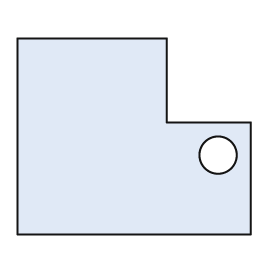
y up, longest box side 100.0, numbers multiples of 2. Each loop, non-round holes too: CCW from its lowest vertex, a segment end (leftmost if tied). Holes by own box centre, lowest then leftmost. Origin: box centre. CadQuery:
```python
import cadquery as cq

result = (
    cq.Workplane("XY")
    .moveTo(-50.0, -42.0)
    .lineTo(50.0, -42.0)
    .lineTo(50.0, 6.0)
    .lineTo(14.0, 6.0)
    .lineTo(14.0, 42.0)
    .lineTo(-50.0, 42.0)
    .close()
    .moveTo(36.0, -8.0)
    .circle(8.0)
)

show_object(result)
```